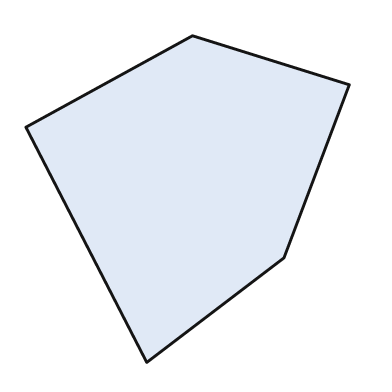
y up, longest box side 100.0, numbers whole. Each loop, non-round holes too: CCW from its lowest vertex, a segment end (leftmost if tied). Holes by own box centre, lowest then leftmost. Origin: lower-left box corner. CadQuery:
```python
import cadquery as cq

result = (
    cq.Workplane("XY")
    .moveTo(37.0, 0.0)
    .lineTo(79.0, 32.0)
    .lineTo(99.0, 85.0)
    .lineTo(51.0, 100.0)
    .lineTo(0.0, 72.0)
    .close()
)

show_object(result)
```